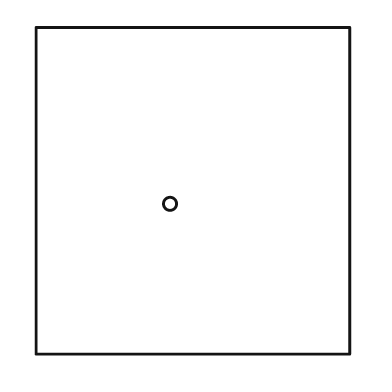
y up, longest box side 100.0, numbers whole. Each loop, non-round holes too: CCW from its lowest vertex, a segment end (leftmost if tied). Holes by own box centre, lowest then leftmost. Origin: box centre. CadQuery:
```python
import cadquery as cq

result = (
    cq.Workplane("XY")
    .moveTo(-48.0, -50.0)
    .lineTo(48.0, -50.0)
    .lineTo(48.0, 50.0)
    .lineTo(-48.0, 50.0)
    .close()
    .moveTo(-7.0, -4.0)
    .circle(2.0)
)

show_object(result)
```